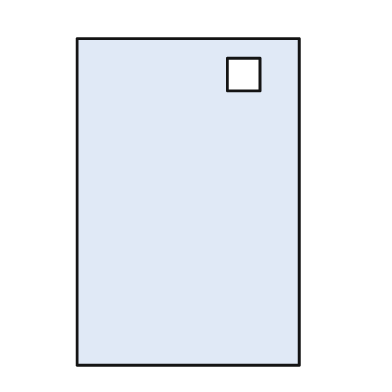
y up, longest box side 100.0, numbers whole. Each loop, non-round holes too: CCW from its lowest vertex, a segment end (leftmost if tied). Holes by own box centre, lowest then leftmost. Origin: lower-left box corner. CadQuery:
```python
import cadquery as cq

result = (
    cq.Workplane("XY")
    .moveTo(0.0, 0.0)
    .lineTo(68.0, 0.0)
    .lineTo(68.0, 100.0)
    .lineTo(0.0, 100.0)
    .close()
    .moveTo(46.0, 84.0)
    .lineTo(56.0, 84.0)
    .lineTo(56.0, 94.0)
    .lineTo(46.0, 94.0)
    .close()
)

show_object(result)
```